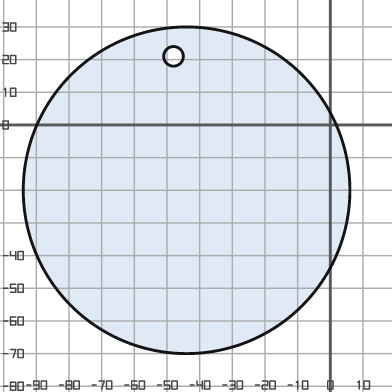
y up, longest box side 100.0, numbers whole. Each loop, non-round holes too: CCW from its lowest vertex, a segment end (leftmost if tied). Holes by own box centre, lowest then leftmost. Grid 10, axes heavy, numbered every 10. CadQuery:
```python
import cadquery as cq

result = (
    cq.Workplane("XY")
    .moveTo(-44.0, -20.0)
    .circle(50.0)
    .moveTo(-48.0, 21.0)
    .circle(3.0)
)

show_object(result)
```